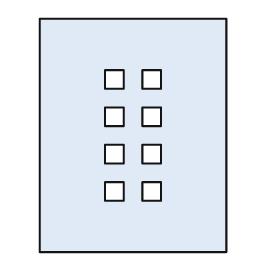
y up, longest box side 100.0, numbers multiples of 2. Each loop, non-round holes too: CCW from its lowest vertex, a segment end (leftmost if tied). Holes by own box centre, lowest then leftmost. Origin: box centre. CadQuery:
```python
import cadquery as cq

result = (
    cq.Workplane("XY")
    .moveTo(-40.0, -50.0)
    .lineTo(40.0, -50.0)
    .lineTo(40.0, 50.0)
    .lineTo(-40.0, 50.0)
    .close()
    .moveTo(-12.0, -28.0)
    .lineTo(-4.0, -28.0)
    .lineTo(-4.0, -20.0)
    .lineTo(-12.0, -20.0)
    .close()
    .moveTo(4.0, -28.0)
    .lineTo(12.0, -28.0)
    .lineTo(12.0, -20.0)
    .lineTo(4.0, -20.0)
    .close()
    .moveTo(-12.0, -12.0)
    .lineTo(-4.0, -12.0)
    .lineTo(-4.0, -4.0)
    .lineTo(-12.0, -4.0)
    .close()
    .moveTo(4.0, -12.0)
    .lineTo(12.0, -12.0)
    .lineTo(12.0, -4.0)
    .lineTo(4.0, -4.0)
    .close()
    .moveTo(-12.0, 4.0)
    .lineTo(-4.0, 4.0)
    .lineTo(-4.0, 12.0)
    .lineTo(-12.0, 12.0)
    .close()
    .moveTo(4.0, 4.0)
    .lineTo(12.0, 4.0)
    .lineTo(12.0, 12.0)
    .lineTo(4.0, 12.0)
    .close()
    .moveTo(-12.0, 20.0)
    .lineTo(-4.0, 20.0)
    .lineTo(-4.0, 28.0)
    .lineTo(-12.0, 28.0)
    .close()
    .moveTo(4.0, 20.0)
    .lineTo(12.0, 20.0)
    .lineTo(12.0, 28.0)
    .lineTo(4.0, 28.0)
    .close()
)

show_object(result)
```